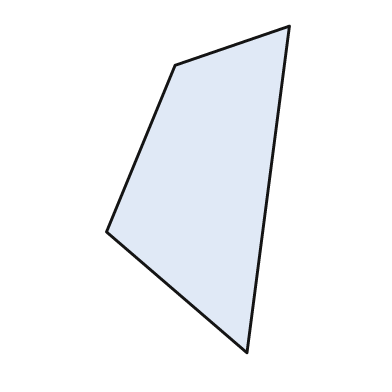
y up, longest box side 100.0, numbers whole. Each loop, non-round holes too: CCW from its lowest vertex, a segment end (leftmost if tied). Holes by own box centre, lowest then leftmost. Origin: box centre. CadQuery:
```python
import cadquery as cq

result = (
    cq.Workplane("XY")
    .moveTo(15.0, -50.0)
    .lineTo(28.0, 50.0)
    .lineTo(-7.0, 38.0)
    .lineTo(-28.0, -13.0)
    .close()
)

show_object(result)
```